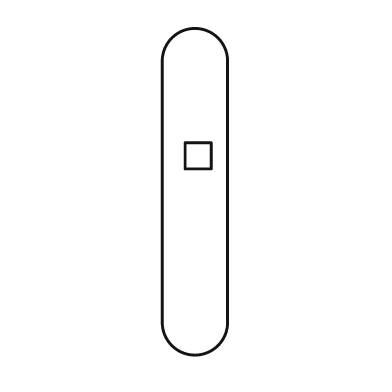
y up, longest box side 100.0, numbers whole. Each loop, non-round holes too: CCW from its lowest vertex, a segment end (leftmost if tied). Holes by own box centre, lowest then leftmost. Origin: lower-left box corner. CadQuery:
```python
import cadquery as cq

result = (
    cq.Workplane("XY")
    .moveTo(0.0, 10.0)
    .threePointArc((10.0, 0.0), (20.0, 10.0))
    .lineTo(20.0, 90.0)
    .threePointArc((10.0, 100.0), (0.0, 90.0))
    .close()
    .moveTo(7.0, 57.0)
    .lineTo(15.0, 57.0)
    .lineTo(15.0, 65.0)
    .lineTo(7.0, 65.0)
    .close()
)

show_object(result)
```